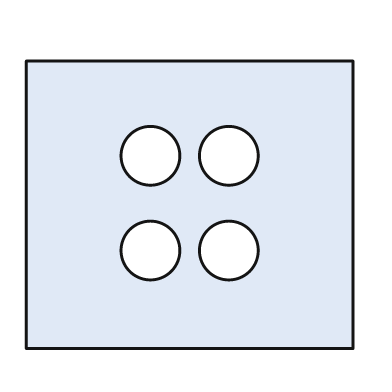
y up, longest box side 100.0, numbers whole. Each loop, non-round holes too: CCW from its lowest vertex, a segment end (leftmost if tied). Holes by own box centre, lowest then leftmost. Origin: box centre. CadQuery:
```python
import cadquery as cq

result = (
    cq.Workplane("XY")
    .moveTo(-50.0, -44.0)
    .lineTo(50.0, -44.0)
    .lineTo(50.0, 44.0)
    .lineTo(-50.0, 44.0)
    .close()
    .moveTo(-12.0, -14.0)
    .circle(9.0)
    .moveTo(12.0, -14.0)
    .circle(9.0)
    .moveTo(-12.0, 15.0)
    .circle(9.0)
    .moveTo(12.0, 15.0)
    .circle(9.0)
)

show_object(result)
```